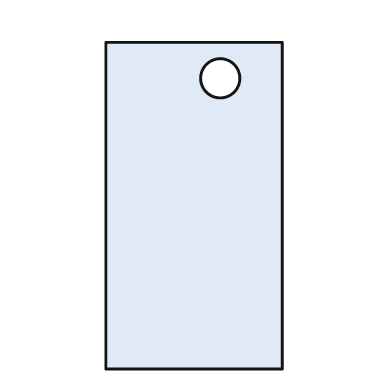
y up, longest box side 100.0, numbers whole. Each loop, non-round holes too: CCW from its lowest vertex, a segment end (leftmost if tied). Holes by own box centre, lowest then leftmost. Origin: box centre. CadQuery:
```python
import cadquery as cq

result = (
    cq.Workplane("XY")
    .moveTo(-27.0, -50.0)
    .lineTo(27.0, -50.0)
    .lineTo(27.0, 50.0)
    .lineTo(-27.0, 50.0)
    .close()
    .moveTo(8.0, 39.0)
    .circle(6.0)
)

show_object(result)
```